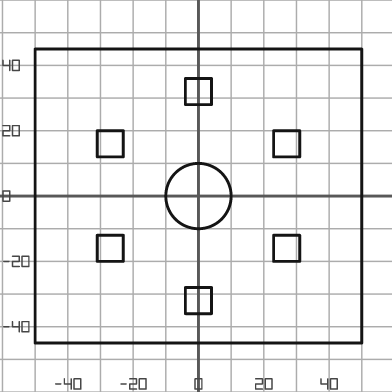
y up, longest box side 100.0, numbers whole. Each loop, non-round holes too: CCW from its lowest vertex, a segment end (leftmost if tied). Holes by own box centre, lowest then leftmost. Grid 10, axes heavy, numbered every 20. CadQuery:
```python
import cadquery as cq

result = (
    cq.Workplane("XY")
    .moveTo(-50.0, -45.0)
    .lineTo(50.0, -45.0)
    .lineTo(50.0, 45.0)
    .lineTo(-50.0, 45.0)
    .close()
    .moveTo(-4.0, -36.0)
    .lineTo(4.0, -36.0)
    .lineTo(4.0, -28.0)
    .lineTo(-4.0, -28.0)
    .close()
    .moveTo(-31.0, -20.0)
    .lineTo(-23.0, -20.0)
    .lineTo(-23.0, -12.0)
    .lineTo(-31.0, -12.0)
    .close()
    .moveTo(23.0, -20.0)
    .lineTo(31.0, -20.0)
    .lineTo(31.0, -12.0)
    .lineTo(23.0, -12.0)
    .close()
    .moveTo(0.0, 0.0)
    .circle(10.0)
    .moveTo(-31.0, 12.0)
    .lineTo(-23.0, 12.0)
    .lineTo(-23.0, 20.0)
    .lineTo(-31.0, 20.0)
    .close()
    .moveTo(23.0, 12.0)
    .lineTo(31.0, 12.0)
    .lineTo(31.0, 20.0)
    .lineTo(23.0, 20.0)
    .close()
    .moveTo(-4.0, 28.0)
    .lineTo(4.0, 28.0)
    .lineTo(4.0, 36.0)
    .lineTo(-4.0, 36.0)
    .close()
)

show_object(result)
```